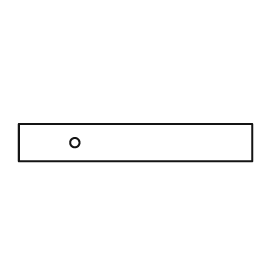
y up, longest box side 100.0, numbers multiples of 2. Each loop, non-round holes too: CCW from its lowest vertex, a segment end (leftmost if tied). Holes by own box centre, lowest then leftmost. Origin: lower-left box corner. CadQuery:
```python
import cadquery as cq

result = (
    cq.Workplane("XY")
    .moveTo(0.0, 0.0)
    .lineTo(100.0, 0.0)
    .lineTo(100.0, 16.0)
    .lineTo(0.0, 16.0)
    .close()
    .moveTo(24.0, 8.0)
    .circle(2.0)
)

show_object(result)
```